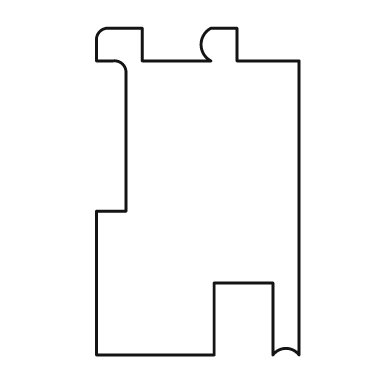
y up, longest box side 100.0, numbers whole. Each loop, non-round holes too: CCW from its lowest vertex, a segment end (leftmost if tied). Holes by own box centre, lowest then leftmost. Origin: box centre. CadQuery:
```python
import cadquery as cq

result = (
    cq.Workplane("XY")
    .moveTo(-31.0, -50.0)
    .lineTo(5.0, -50.0)
    .lineTo(5.0, -28.0)
    .lineTo(23.0, -28.0)
    .lineTo(23.0, -50.0)
    .threePointArc((27.0, -48.0), (31.0, -50.0))
    .lineTo(31.0, 40.0)
    .lineTo(12.0, 40.0)
    .lineTo(12.0, 50.0)
    .lineTo(4.0, 50.0)
    .threePointArc((1.0, 45.0), (4.0, 40.0))
    .lineTo(-17.0, 40.0)
    .lineTo(-17.0, 50.0)
    .lineTo(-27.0, 50.0)
    .threePointArc((-30.0, 49.0), (-31.0, 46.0))
    .lineTo(-31.0, 40.0)
    .lineTo(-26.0, 40.0)
    .threePointArc((-23.0, 39.0), (-22.0, 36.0))
    .lineTo(-22.0, -6.0)
    .lineTo(-31.0, -6.0)
    .close()
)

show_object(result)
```